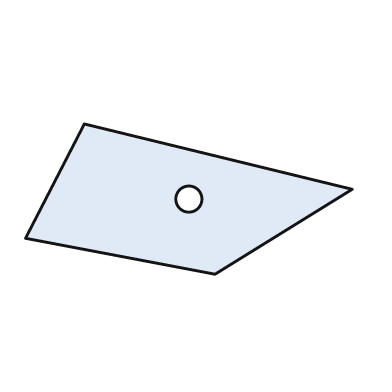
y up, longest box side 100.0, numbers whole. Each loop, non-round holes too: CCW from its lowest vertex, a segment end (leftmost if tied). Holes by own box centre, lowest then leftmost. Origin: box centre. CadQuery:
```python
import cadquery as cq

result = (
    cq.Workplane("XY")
    .moveTo(8.0, -23.0)
    .lineTo(50.0, 3.0)
    .lineTo(-32.0, 23.0)
    .lineTo(-50.0, -12.0)
    .close()
    .moveTo(0.0, 0.0)
    .circle(4.0)
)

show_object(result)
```